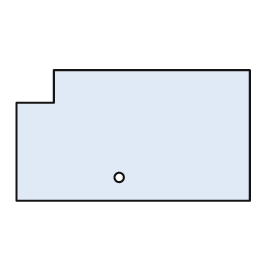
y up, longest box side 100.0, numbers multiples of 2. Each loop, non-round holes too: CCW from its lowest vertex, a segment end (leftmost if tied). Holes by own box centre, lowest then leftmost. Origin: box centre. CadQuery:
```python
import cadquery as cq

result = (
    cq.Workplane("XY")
    .moveTo(-50.0, -28.0)
    .lineTo(50.0, -28.0)
    .lineTo(50.0, 28.0)
    .lineTo(-34.0, 28.0)
    .lineTo(-34.0, 14.0)
    .lineTo(-50.0, 14.0)
    .close()
    .moveTo(-6.0, -18.0)
    .circle(2.0)
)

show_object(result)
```